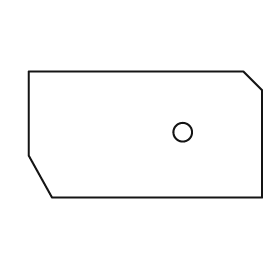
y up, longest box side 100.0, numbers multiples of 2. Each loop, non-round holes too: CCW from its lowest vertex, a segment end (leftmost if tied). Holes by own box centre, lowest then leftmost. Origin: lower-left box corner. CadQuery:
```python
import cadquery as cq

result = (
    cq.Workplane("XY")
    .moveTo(10.0, 0.0)
    .lineTo(100.0, 0.0)
    .lineTo(100.0, 46.0)
    .lineTo(92.0, 54.0)
    .lineTo(0.0, 54.0)
    .lineTo(0.0, 18.0)
    .close()
    .moveTo(66.0, 28.0)
    .circle(4.0)
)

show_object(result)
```